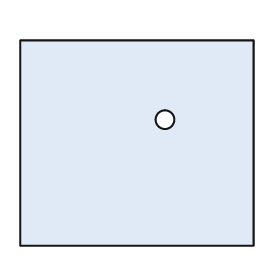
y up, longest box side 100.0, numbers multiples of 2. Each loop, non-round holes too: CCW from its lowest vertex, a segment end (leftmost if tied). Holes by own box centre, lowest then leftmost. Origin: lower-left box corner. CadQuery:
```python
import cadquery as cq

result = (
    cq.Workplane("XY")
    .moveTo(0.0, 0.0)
    .lineTo(100.0, 0.0)
    .lineTo(100.0, 88.0)
    .lineTo(0.0, 88.0)
    .close()
    .moveTo(62.0, 54.0)
    .circle(4.0)
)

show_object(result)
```